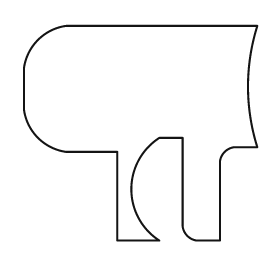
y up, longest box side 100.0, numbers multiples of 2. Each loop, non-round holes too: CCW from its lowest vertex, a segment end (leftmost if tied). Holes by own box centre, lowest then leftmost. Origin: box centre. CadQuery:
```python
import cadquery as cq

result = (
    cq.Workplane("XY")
    .moveTo(-10.0, -46.0)
    .lineTo(8.0, -46.0)
    .threePointArc((-4.0, -24.0), (8.0, -2.0))
    .lineTo(18.0, -2.0)
    .lineTo(18.0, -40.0)
    .threePointArc((20.0, -44.0), (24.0, -46.0))
    .lineTo(34.0, -46.0)
    .lineTo(34.0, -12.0)
    .threePointArc((36.0, -8.0), (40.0, -6.0))
    .lineTo(50.0, -6.0)
    .threePointArc((46.0, 20.0), (50.0, 46.0))
    .lineTo(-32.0, 46.0)
    .threePointArc((-44.0, 40.0), (-50.0, 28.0))
    .lineTo(-50.0, 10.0)
    .threePointArc((-44.0, -2.0), (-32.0, -8.0))
    .lineTo(-10.0, -8.0)
    .close()
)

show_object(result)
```